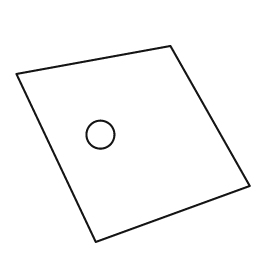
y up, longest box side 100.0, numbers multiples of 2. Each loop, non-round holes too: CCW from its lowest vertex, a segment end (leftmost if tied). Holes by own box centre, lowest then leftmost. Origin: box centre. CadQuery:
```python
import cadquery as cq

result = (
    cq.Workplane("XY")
    .moveTo(-16.0, -42.0)
    .lineTo(50.0, -18.0)
    .lineTo(16.0, 42.0)
    .lineTo(-50.0, 30.0)
    .close()
    .moveTo(-14.0, 4.0)
    .circle(6.0)
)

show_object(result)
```